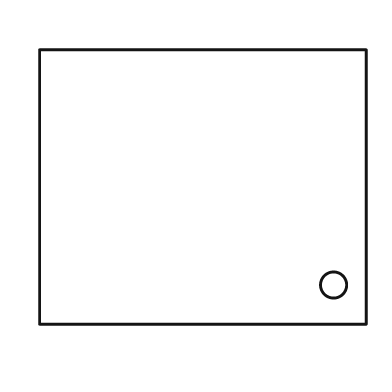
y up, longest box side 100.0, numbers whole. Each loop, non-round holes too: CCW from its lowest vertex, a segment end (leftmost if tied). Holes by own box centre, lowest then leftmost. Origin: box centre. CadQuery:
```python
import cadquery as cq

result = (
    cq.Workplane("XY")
    .moveTo(-50.0, -42.0)
    .lineTo(50.0, -42.0)
    .lineTo(50.0, 42.0)
    .lineTo(-50.0, 42.0)
    .close()
    .moveTo(40.0, -30.0)
    .circle(4.0)
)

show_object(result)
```